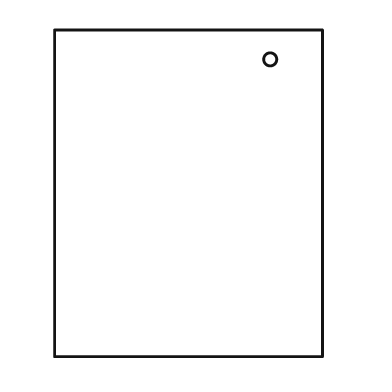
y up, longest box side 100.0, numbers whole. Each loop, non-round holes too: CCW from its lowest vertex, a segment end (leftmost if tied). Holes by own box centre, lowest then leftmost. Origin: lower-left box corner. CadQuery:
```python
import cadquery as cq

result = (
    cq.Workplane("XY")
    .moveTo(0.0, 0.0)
    .lineTo(82.0, 0.0)
    .lineTo(82.0, 100.0)
    .lineTo(0.0, 100.0)
    .close()
    .moveTo(66.0, 91.0)
    .circle(2.0)
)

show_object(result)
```